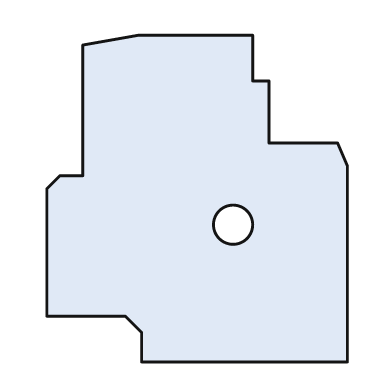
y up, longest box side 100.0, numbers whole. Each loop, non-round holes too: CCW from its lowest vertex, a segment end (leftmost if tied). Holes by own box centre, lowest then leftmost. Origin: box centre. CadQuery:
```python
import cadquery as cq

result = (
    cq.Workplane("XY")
    .moveTo(-17.0, -50.0)
    .lineTo(46.0, -50.0)
    .lineTo(46.0, 10.0)
    .lineTo(43.0, 17.0)
    .lineTo(22.0, 17.0)
    .lineTo(22.0, 36.0)
    .lineTo(17.0, 36.0)
    .lineTo(17.0, 50.0)
    .lineTo(-18.0, 50.0)
    .lineTo(-35.0, 47.0)
    .lineTo(-35.0, 7.0)
    .lineTo(-42.0, 7.0)
    .lineTo(-46.0, 3.0)
    .lineTo(-46.0, -36.0)
    .lineTo(-22.0, -36.0)
    .lineTo(-17.0, -41.0)
    .close()
    .moveTo(11.0, -8.0)
    .circle(6.0)
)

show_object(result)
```